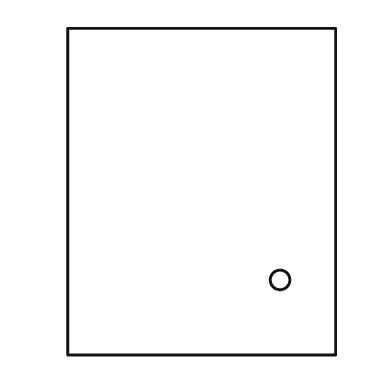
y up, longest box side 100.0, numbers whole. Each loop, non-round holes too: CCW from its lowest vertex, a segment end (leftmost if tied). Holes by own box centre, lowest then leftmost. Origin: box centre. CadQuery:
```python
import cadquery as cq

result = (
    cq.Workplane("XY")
    .moveTo(-41.0, -50.0)
    .lineTo(41.0, -50.0)
    .lineTo(41.0, 50.0)
    .lineTo(-41.0, 50.0)
    .close()
    .moveTo(24.0, -27.0)
    .circle(3.0)
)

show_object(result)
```